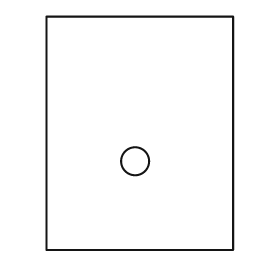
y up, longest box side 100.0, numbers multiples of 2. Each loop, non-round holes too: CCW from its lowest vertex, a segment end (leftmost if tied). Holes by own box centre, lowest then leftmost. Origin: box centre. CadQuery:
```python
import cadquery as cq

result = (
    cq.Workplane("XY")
    .moveTo(-40.0, -50.0)
    .lineTo(40.0, -50.0)
    .lineTo(40.0, 50.0)
    .lineTo(-40.0, 50.0)
    .close()
    .moveTo(-2.0, -12.0)
    .circle(6.0)
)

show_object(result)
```